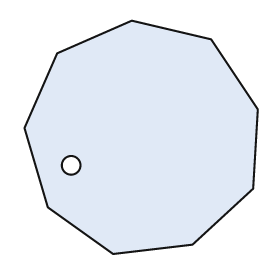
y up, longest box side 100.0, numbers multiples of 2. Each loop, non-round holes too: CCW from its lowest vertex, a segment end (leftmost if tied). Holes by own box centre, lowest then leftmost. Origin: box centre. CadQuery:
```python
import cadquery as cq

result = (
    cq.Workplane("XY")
    .moveTo(-12.0, -50.0)
    .lineTo(22.0, -46.0)
    .lineTo(48.0, -22.0)
    .lineTo(50.0, 12.0)
    .lineTo(30.0, 42.0)
    .lineTo(-4.0, 50.0)
    .lineTo(-36.0, 36.0)
    .lineTo(-50.0, 4.0)
    .lineTo(-40.0, -30.0)
    .close()
    .moveTo(-30.0, -12.0)
    .circle(4.0)
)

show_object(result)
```